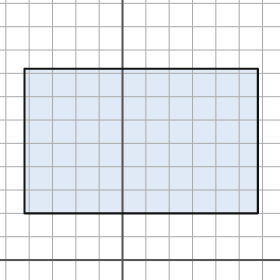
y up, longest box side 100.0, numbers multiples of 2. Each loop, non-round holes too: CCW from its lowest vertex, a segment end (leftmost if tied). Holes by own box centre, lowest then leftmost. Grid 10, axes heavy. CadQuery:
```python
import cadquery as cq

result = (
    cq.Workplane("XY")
    .moveTo(-42.0, 20.0)
    .lineTo(58.0, 20.0)
    .lineTo(58.0, 82.0)
    .lineTo(-42.0, 82.0)
    .close()
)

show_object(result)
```